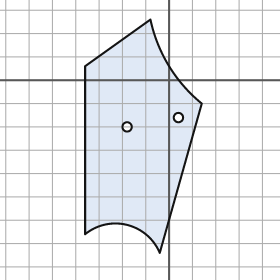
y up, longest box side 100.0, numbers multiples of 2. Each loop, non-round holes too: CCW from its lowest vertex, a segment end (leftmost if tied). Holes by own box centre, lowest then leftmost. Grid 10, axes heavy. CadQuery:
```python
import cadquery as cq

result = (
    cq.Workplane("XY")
    .moveTo(-4.0, -74.0)
    .lineTo(14.0, -10.0)
    .threePointArc((0.0, 6.0), (-8.0, 26.0))
    .lineTo(-36.0, 6.0)
    .lineTo(-36.0, -66.0)
    .threePointArc((-18.0, -62.0), (-4.0, -74.0))
    .close()
    .moveTo(-18.0, -20.0)
    .circle(2.0)
    .moveTo(4.0, -16.0)
    .circle(2.0)
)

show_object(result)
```